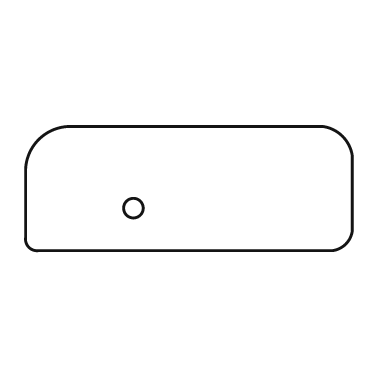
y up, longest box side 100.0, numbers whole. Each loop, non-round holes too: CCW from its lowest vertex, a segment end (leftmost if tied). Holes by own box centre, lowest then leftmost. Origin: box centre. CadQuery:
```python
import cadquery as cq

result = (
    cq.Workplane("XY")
    .moveTo(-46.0, -19.0)
    .lineTo(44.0, -19.0)
    .threePointArc((48.0, -17.0), (50.0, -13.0))
    .lineTo(50.0, 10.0)
    .threePointArc((47.0, 16.0), (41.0, 19.0))
    .lineTo(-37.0, 19.0)
    .threePointArc((-46.0, 15.0), (-50.0, 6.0))
    .lineTo(-50.0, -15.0)
    .threePointArc((-49.0, -18.0), (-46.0, -19.0))
    .close()
    .moveTo(-17.0, -6.0)
    .circle(3.0)
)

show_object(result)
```